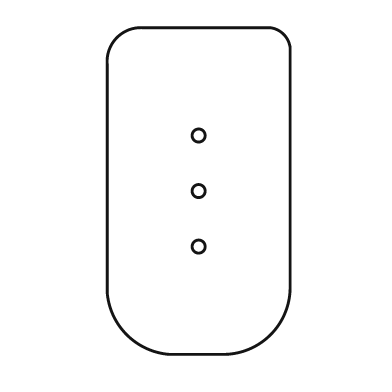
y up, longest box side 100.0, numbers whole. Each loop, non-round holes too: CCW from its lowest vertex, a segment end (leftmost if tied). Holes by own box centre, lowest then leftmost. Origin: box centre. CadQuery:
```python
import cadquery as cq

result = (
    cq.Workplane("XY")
    .moveTo(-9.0, -50.0)
    .lineTo(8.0, -50.0)
    .threePointArc((22.0, -44.0), (28.0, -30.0))
    .lineTo(28.0, 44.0)
    .threePointArc((26.0, 48.0), (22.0, 50.0))
    .lineTo(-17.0, 50.0)
    .threePointArc((-25.0, 47.0), (-28.0, 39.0))
    .lineTo(-28.0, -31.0)
    .threePointArc((-22.0, -44.0), (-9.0, -50.0))
    .close()
    .moveTo(0.0, -17.0)
    .circle(2.0)
    .moveTo(0.0, 0.0)
    .circle(2.0)
    .moveTo(0.0, 17.0)
    .circle(2.0)
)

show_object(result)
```